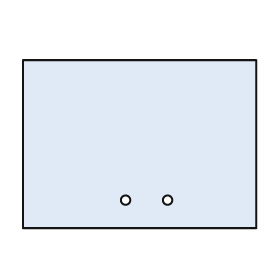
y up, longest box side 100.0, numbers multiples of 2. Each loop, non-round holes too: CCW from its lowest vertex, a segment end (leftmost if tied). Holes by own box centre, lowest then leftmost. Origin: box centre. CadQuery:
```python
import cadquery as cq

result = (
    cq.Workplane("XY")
    .moveTo(-50.0, -36.0)
    .lineTo(50.0, -36.0)
    .lineTo(50.0, 36.0)
    .lineTo(-50.0, 36.0)
    .close()
    .moveTo(-6.0, -24.0)
    .circle(2.0)
    .moveTo(12.0, -24.0)
    .circle(2.0)
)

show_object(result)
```